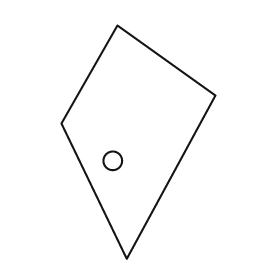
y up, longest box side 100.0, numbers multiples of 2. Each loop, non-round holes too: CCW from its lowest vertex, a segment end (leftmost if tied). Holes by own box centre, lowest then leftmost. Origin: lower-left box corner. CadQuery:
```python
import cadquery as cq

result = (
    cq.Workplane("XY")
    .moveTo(28.0, 0.0)
    .lineTo(66.0, 70.0)
    .lineTo(24.0, 100.0)
    .lineTo(0.0, 58.0)
    .close()
    .moveTo(22.0, 42.0)
    .circle(4.0)
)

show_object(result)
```